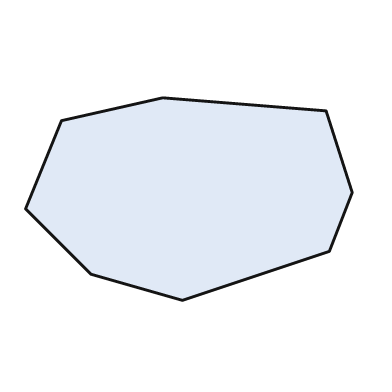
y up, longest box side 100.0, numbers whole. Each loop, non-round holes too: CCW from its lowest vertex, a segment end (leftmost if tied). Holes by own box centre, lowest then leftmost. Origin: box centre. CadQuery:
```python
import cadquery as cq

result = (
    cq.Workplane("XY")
    .moveTo(-2.0, -31.0)
    .lineTo(43.0, -16.0)
    .lineTo(50.0, 2.0)
    .lineTo(42.0, 27.0)
    .lineTo(-8.0, 31.0)
    .lineTo(-39.0, 24.0)
    .lineTo(-50.0, -3.0)
    .lineTo(-30.0, -23.0)
    .close()
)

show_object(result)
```